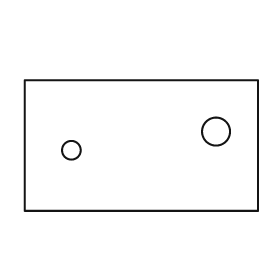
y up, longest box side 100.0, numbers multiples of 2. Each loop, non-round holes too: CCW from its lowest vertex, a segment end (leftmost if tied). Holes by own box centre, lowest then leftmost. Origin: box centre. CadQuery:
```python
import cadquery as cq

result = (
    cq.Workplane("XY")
    .moveTo(-50.0, -28.0)
    .lineTo(50.0, -28.0)
    .lineTo(50.0, 28.0)
    .lineTo(-50.0, 28.0)
    .close()
    .moveTo(-30.0, -2.0)
    .circle(4.0)
    .moveTo(32.0, 6.0)
    .circle(6.0)
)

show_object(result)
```